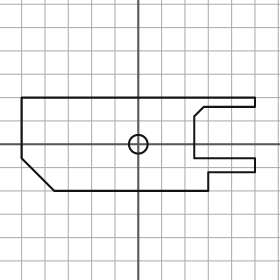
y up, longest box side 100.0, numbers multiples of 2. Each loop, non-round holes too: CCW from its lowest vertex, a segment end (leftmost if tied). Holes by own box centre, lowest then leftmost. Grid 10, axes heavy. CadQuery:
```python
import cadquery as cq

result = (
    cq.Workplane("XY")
    .moveTo(-36.0, -20.0)
    .lineTo(30.0, -20.0)
    .lineTo(30.0, -12.0)
    .lineTo(50.0, -12.0)
    .lineTo(50.0, -6.0)
    .lineTo(24.0, -6.0)
    .lineTo(24.0, 12.0)
    .lineTo(28.0, 16.0)
    .lineTo(50.0, 16.0)
    .lineTo(50.0, 20.0)
    .lineTo(-50.0, 20.0)
    .lineTo(-50.0, -6.0)
    .close()
    .moveTo(0.0, 0.0)
    .circle(4.0)
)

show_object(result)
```